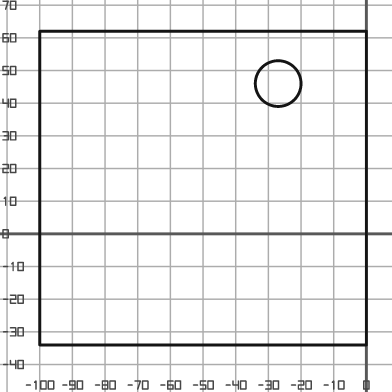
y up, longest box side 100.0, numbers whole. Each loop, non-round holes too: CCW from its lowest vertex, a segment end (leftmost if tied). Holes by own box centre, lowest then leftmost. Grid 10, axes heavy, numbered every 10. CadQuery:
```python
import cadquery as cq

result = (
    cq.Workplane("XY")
    .moveTo(-100.0, -34.0)
    .lineTo(0.0, -34.0)
    .lineTo(0.0, 62.0)
    .lineTo(-100.0, 62.0)
    .close()
    .moveTo(-27.0, 46.0)
    .circle(7.0)
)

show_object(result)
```